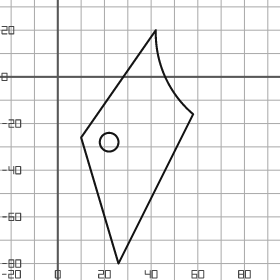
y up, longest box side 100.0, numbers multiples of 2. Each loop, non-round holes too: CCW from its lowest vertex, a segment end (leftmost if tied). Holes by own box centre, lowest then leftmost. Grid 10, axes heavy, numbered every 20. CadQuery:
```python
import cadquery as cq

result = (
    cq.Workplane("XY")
    .moveTo(26.0, -80.0)
    .lineTo(58.0, -16.0)
    .threePointArc((46.0, 0.0), (42.0, 20.0))
    .lineTo(10.0, -26.0)
    .close()
    .moveTo(22.0, -28.0)
    .circle(4.0)
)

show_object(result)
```